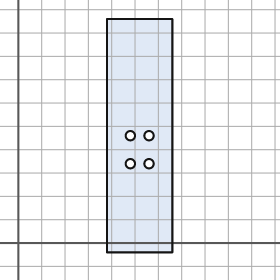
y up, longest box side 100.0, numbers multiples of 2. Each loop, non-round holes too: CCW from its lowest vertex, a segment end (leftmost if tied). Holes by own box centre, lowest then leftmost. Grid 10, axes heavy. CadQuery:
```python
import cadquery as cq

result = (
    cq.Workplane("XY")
    .moveTo(38.0, -4.0)
    .lineTo(66.0, -4.0)
    .lineTo(66.0, 96.0)
    .lineTo(38.0, 96.0)
    .close()
    .moveTo(48.0, 34.0)
    .circle(2.0)
    .moveTo(56.0, 34.0)
    .circle(2.0)
    .moveTo(48.0, 46.0)
    .circle(2.0)
    .moveTo(56.0, 46.0)
    .circle(2.0)
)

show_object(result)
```